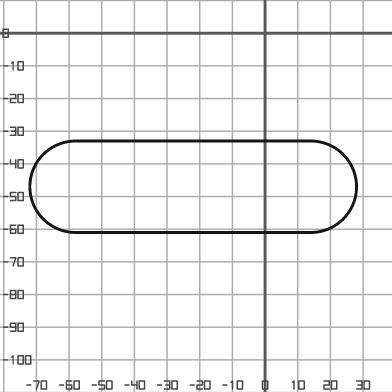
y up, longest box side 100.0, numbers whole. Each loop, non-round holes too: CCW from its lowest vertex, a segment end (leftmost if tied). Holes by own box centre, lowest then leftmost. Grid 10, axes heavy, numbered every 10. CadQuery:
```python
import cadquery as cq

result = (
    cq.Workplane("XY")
    .moveTo(-58.0, -61.0)
    .lineTo(14.0, -61.0)
    .threePointArc((28.0, -47.0), (14.0, -33.0))
    .lineTo(-58.0, -33.0)
    .threePointArc((-72.0, -47.0), (-58.0, -61.0))
    .close()
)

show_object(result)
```